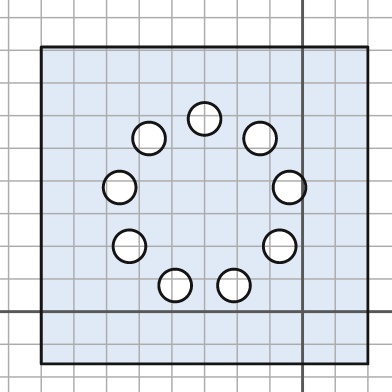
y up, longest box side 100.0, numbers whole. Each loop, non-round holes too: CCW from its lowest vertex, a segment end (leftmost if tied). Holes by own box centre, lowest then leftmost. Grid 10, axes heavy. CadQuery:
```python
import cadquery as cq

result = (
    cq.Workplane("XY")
    .moveTo(-80.0, -16.0)
    .lineTo(20.0, -16.0)
    .lineTo(20.0, 81.0)
    .lineTo(-80.0, 81.0)
    .close()
    .moveTo(-39.0, 8.0)
    .circle(5.0)
    .moveTo(-21.0, 8.0)
    .circle(5.0)
    .moveTo(-53.0, 20.0)
    .circle(5.0)
    .moveTo(-7.0, 20.0)
    .circle(5.0)
    .moveTo(-56.0, 38.0)
    .circle(5.0)
    .moveTo(-4.0, 38.0)
    .circle(5.0)
    .moveTo(-47.0, 53.0)
    .circle(5.0)
    .moveTo(-13.0, 53.0)
    .circle(5.0)
    .moveTo(-30.0, 59.0)
    .circle(5.0)
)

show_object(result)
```